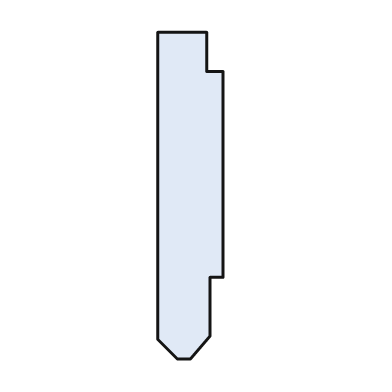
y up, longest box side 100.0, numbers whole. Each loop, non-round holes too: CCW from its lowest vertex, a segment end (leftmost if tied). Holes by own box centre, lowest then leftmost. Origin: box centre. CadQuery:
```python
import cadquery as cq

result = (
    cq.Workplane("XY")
    .moveTo(-4.0, -50.0)
    .lineTo(0.0, -50.0)
    .lineTo(6.0, -43.0)
    .lineTo(6.0, -25.0)
    .lineTo(10.0, -25.0)
    .lineTo(10.0, 38.0)
    .lineTo(5.0, 38.0)
    .lineTo(5.0, 50.0)
    .lineTo(-10.0, 50.0)
    .lineTo(-10.0, -44.0)
    .close()
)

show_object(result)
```